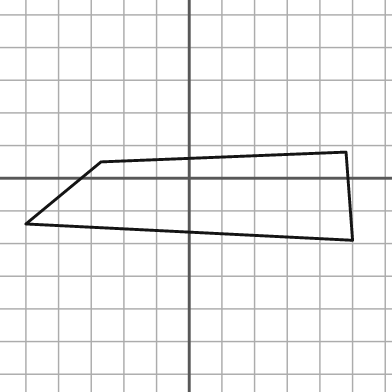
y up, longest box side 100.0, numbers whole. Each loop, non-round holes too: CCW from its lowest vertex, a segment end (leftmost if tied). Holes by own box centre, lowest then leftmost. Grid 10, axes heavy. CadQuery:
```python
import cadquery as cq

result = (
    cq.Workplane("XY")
    .moveTo(50.0, -19.0)
    .lineTo(48.0, 8.0)
    .lineTo(-27.0, 5.0)
    .lineTo(-50.0, -14.0)
    .close()
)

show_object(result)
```